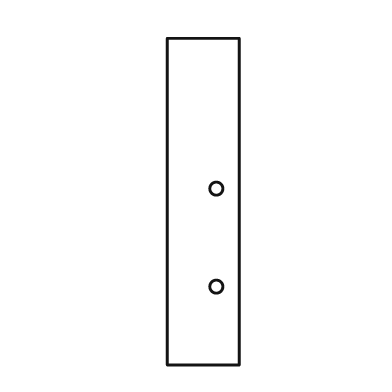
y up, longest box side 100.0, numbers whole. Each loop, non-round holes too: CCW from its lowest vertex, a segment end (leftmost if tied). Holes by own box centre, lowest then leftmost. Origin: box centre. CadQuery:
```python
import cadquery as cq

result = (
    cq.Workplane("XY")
    .moveTo(-11.0, -50.0)
    .lineTo(11.0, -50.0)
    .lineTo(11.0, 50.0)
    .lineTo(-11.0, 50.0)
    .close()
    .moveTo(4.0, -26.0)
    .circle(2.0)
    .moveTo(4.0, 4.0)
    .circle(2.0)
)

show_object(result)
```